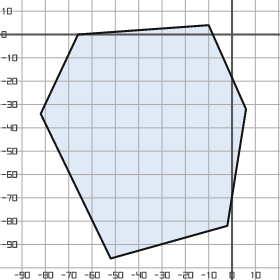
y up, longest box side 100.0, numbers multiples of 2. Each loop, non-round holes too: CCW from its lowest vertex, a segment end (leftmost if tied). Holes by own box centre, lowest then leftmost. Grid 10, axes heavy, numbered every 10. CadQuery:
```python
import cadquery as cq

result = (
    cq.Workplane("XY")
    .moveTo(-52.0, -96.0)
    .lineTo(-2.0, -82.0)
    .lineTo(6.0, -32.0)
    .lineTo(-10.0, 4.0)
    .lineTo(-66.0, 0.0)
    .lineTo(-82.0, -34.0)
    .close()
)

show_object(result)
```